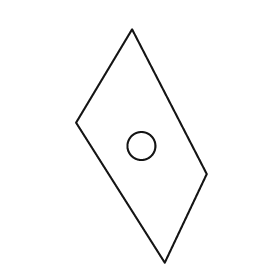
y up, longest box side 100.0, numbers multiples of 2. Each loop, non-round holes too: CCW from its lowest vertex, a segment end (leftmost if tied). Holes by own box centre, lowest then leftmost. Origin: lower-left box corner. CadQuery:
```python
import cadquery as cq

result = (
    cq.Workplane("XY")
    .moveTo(38.0, 0.0)
    .lineTo(56.0, 38.0)
    .lineTo(24.0, 100.0)
    .lineTo(0.0, 60.0)
    .close()
    .moveTo(28.0, 50.0)
    .circle(6.0)
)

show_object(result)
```